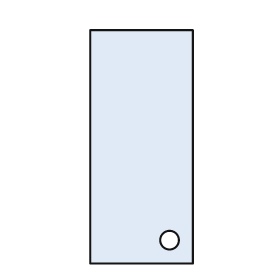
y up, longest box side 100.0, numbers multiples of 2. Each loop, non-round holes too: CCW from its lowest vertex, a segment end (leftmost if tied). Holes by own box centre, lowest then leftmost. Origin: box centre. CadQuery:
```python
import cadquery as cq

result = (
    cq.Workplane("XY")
    .moveTo(-22.0, -50.0)
    .lineTo(22.0, -50.0)
    .lineTo(22.0, 50.0)
    .lineTo(-22.0, 50.0)
    .close()
    .moveTo(12.0, -40.0)
    .circle(4.0)
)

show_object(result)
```